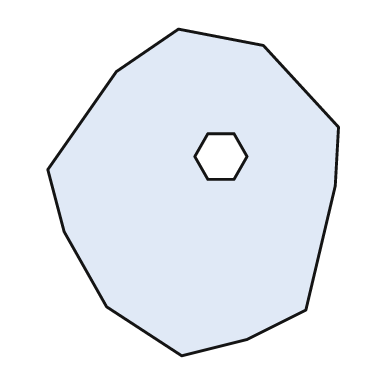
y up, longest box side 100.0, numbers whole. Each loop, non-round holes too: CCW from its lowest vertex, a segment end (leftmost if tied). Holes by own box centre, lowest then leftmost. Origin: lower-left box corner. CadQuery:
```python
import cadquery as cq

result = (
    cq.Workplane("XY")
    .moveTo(41.0, 0.0)
    .lineTo(61.0, 5.0)
    .lineTo(79.0, 14.0)
    .lineTo(88.0, 52.0)
    .lineTo(89.0, 70.0)
    .lineTo(66.0, 95.0)
    .lineTo(40.0, 100.0)
    .lineTo(21.0, 87.0)
    .lineTo(0.0, 57.0)
    .lineTo(5.0, 38.0)
    .lineTo(18.0, 15.0)
    .close()
    .moveTo(49.0, 54.0)
    .lineTo(57.0, 54.0)
    .lineTo(61.0, 61.0)
    .lineTo(57.0, 68.0)
    .lineTo(49.0, 68.0)
    .lineTo(45.0, 61.0)
    .close()
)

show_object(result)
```